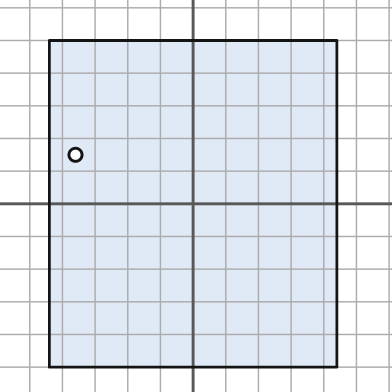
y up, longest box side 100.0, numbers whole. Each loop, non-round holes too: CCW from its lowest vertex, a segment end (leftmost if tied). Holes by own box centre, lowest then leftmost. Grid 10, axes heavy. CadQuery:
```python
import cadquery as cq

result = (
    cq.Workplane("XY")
    .moveTo(-44.0, -50.0)
    .lineTo(44.0, -50.0)
    .lineTo(44.0, 50.0)
    .lineTo(-44.0, 50.0)
    .close()
    .moveTo(-36.0, 15.0)
    .circle(2.0)
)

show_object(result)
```